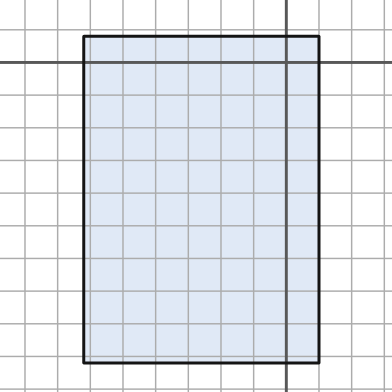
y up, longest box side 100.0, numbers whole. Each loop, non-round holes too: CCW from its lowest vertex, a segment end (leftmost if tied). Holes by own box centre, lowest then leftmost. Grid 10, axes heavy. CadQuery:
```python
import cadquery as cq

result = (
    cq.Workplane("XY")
    .moveTo(-62.0, -92.0)
    .lineTo(10.0, -92.0)
    .lineTo(10.0, 8.0)
    .lineTo(-62.0, 8.0)
    .close()
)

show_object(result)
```